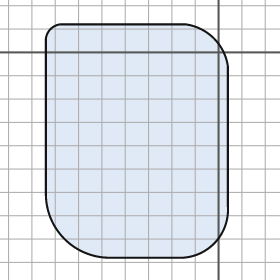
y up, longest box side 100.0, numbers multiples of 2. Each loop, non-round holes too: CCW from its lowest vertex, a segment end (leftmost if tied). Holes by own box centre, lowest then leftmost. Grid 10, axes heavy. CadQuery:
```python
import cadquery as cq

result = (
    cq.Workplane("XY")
    .moveTo(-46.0, -88.0)
    .lineTo(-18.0, -88.0)
    .threePointArc((-2.0, -82.0), (4.0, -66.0))
    .lineTo(4.0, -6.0)
    .threePointArc((-2.0, 6.0), (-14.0, 12.0))
    .lineTo(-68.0, 12.0)
    .threePointArc((-72.0, 10.0), (-74.0, 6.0))
    .lineTo(-74.0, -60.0)
    .threePointArc((-66.0, -80.0), (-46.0, -88.0))
    .close()
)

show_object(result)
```